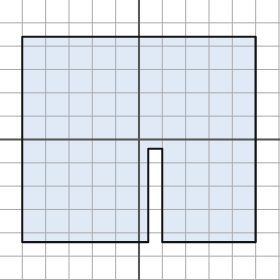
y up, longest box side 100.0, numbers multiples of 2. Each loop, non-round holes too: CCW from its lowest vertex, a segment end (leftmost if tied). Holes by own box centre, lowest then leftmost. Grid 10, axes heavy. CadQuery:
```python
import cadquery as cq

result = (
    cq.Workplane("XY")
    .moveTo(-50.0, -44.0)
    .lineTo(4.0, -44.0)
    .lineTo(4.0, -4.0)
    .lineTo(10.0, -4.0)
    .lineTo(10.0, -44.0)
    .lineTo(50.0, -44.0)
    .lineTo(50.0, 44.0)
    .lineTo(-50.0, 44.0)
    .close()
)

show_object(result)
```